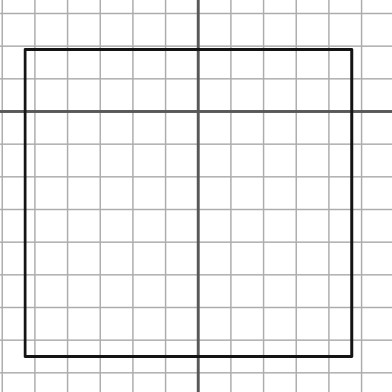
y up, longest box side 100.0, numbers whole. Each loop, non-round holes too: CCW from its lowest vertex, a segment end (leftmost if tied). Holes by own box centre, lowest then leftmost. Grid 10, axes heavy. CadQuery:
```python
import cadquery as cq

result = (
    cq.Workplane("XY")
    .moveTo(-53.0, -75.0)
    .lineTo(47.0, -75.0)
    .lineTo(47.0, 19.0)
    .lineTo(-53.0, 19.0)
    .close()
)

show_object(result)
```